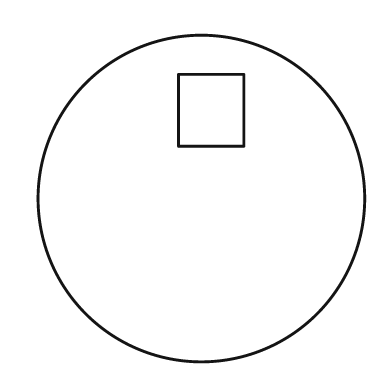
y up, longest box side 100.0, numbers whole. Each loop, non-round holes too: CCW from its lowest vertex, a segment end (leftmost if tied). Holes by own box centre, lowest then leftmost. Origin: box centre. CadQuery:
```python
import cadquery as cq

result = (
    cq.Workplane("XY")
    .moveTo(0.0, 0.0)
    .circle(50.0)
    .moveTo(-7.0, 16.0)
    .lineTo(13.0, 16.0)
    .lineTo(13.0, 38.0)
    .lineTo(-7.0, 38.0)
    .close()
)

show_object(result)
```